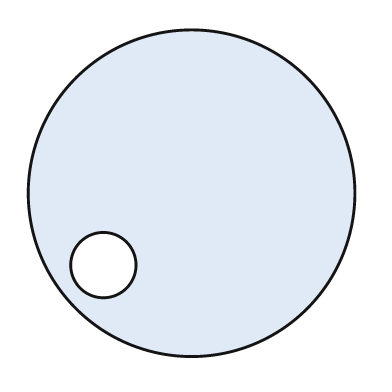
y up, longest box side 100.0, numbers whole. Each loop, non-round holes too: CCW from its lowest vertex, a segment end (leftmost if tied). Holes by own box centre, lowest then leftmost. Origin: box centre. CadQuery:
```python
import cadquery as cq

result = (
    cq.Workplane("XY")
    .moveTo(0.0, 0.0)
    .circle(50.0)
    .moveTo(-27.0, -22.0)
    .circle(10.0)
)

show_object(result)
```